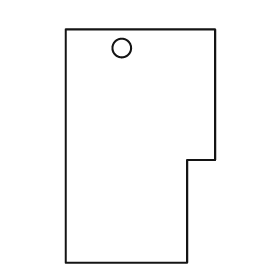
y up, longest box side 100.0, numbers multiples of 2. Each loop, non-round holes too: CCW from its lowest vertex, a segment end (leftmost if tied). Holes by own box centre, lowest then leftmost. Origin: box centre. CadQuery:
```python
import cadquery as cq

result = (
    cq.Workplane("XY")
    .moveTo(-32.0, -50.0)
    .lineTo(20.0, -50.0)
    .lineTo(20.0, -6.0)
    .lineTo(32.0, -6.0)
    .lineTo(32.0, 50.0)
    .lineTo(-32.0, 50.0)
    .close()
    .moveTo(-8.0, 42.0)
    .circle(4.0)
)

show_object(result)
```